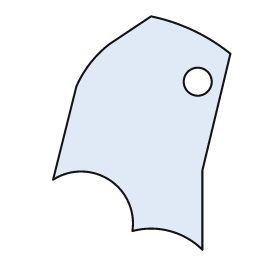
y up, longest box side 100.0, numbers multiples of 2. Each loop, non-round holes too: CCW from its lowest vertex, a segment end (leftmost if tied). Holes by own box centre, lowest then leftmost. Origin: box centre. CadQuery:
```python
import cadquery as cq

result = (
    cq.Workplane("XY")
    .moveTo(26.0, -50.0)
    .lineTo(26.0, -16.0)
    .lineTo(38.0, 34.0)
    .threePointArc((22.0, 44.0), (4.0, 50.0))
    .lineTo(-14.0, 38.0)
    .threePointArc((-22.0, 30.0), (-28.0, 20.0))
    .lineTo(-38.0, -20.0)
    .threePointArc((-14.0, -20.0), (-4.0, -42.0))
    .threePointArc((12.0, -42.0), (26.0, -50.0))
    .close()
    .moveTo(24.0, 22.0)
    .circle(6.0)
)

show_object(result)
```